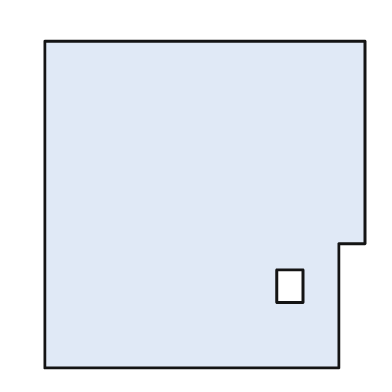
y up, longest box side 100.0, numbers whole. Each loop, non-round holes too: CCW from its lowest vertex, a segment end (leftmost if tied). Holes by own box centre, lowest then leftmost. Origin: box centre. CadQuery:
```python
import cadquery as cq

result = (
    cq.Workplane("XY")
    .moveTo(-49.0, -50.0)
    .lineTo(41.0, -50.0)
    .lineTo(41.0, -12.0)
    .lineTo(49.0, -12.0)
    .lineTo(49.0, 50.0)
    .lineTo(-49.0, 50.0)
    .close()
    .moveTo(22.0, -30.0)
    .lineTo(30.0, -30.0)
    .lineTo(30.0, -20.0)
    .lineTo(22.0, -20.0)
    .close()
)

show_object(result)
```